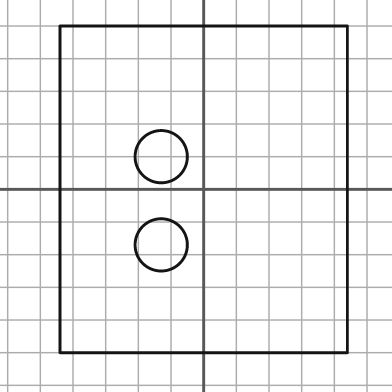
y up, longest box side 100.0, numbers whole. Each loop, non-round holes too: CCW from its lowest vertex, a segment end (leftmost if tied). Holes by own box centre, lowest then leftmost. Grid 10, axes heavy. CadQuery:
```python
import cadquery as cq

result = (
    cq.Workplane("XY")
    .moveTo(-44.0, -50.0)
    .lineTo(44.0, -50.0)
    .lineTo(44.0, 50.0)
    .lineTo(-44.0, 50.0)
    .close()
    .moveTo(-13.0, -17.0)
    .circle(8.0)
    .moveTo(-13.0, 10.0)
    .circle(8.0)
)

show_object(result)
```